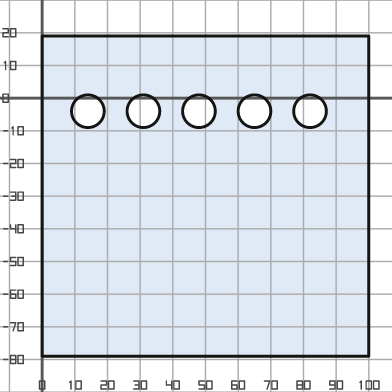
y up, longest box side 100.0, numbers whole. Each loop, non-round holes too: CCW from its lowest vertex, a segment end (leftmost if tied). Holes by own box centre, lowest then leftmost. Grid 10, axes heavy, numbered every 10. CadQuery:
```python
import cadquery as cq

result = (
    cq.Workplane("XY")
    .moveTo(0.0, -79.0)
    .lineTo(100.0, -79.0)
    .lineTo(100.0, 19.0)
    .lineTo(0.0, 19.0)
    .close()
    .moveTo(14.0, -4.0)
    .circle(5.0)
    .moveTo(31.0, -4.0)
    .circle(5.0)
    .moveTo(48.0, -4.0)
    .circle(5.0)
    .moveTo(65.0, -4.0)
    .circle(5.0)
    .moveTo(82.0, -4.0)
    .circle(5.0)
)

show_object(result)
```